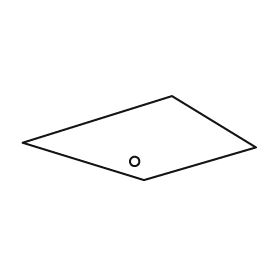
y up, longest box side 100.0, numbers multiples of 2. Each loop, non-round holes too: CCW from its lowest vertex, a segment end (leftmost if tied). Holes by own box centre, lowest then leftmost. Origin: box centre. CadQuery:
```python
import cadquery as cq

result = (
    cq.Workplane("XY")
    .moveTo(2.0, -18.0)
    .lineTo(50.0, -4.0)
    .lineTo(14.0, 18.0)
    .lineTo(-50.0, -2.0)
    .close()
    .moveTo(-2.0, -10.0)
    .circle(2.0)
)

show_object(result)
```